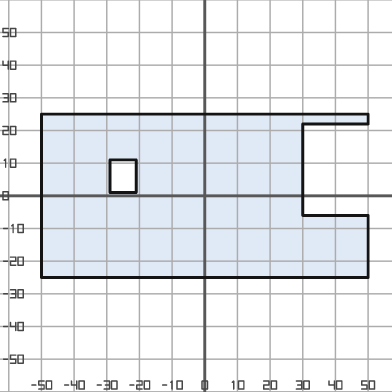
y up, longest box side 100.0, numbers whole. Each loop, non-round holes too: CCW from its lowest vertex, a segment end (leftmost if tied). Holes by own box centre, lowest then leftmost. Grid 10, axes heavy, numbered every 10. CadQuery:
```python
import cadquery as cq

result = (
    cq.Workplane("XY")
    .moveTo(-50.0, -25.0)
    .lineTo(50.0, -25.0)
    .lineTo(50.0, -6.0)
    .lineTo(30.0, -6.0)
    .lineTo(30.0, 22.0)
    .lineTo(50.0, 22.0)
    .lineTo(50.0, 25.0)
    .lineTo(-50.0, 25.0)
    .close()
    .moveTo(-29.0, 1.0)
    .lineTo(-21.0, 1.0)
    .lineTo(-21.0, 11.0)
    .lineTo(-29.0, 11.0)
    .close()
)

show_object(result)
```